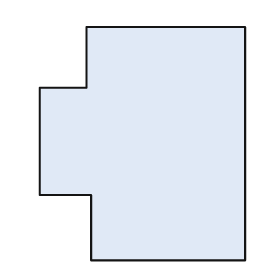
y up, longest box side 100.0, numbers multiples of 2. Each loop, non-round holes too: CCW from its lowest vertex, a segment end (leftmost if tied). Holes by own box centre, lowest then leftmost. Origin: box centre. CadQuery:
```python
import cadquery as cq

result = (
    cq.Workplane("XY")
    .moveTo(-22.0, -50.0)
    .lineTo(44.0, -50.0)
    .lineTo(44.0, 50.0)
    .lineTo(-24.0, 50.0)
    .lineTo(-24.0, 24.0)
    .lineTo(-44.0, 24.0)
    .lineTo(-44.0, -22.0)
    .lineTo(-22.0, -22.0)
    .close()
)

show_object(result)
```